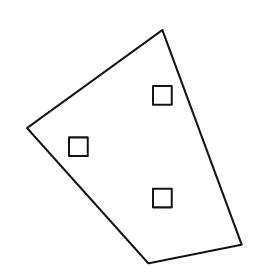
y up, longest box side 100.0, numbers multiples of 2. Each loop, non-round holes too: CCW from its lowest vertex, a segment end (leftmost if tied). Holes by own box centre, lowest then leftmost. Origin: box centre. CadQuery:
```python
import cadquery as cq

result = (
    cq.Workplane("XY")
    .moveTo(6.0, -50.0)
    .lineTo(46.0, -42.0)
    .lineTo(12.0, 50.0)
    .lineTo(-46.0, 8.0)
    .close()
    .moveTo(8.0, -26.0)
    .lineTo(16.0, -26.0)
    .lineTo(16.0, -18.0)
    .lineTo(8.0, -18.0)
    .close()
    .moveTo(-28.0, -4.0)
    .lineTo(-20.0, -4.0)
    .lineTo(-20.0, 4.0)
    .lineTo(-28.0, 4.0)
    .close()
    .moveTo(8.0, 18.0)
    .lineTo(16.0, 18.0)
    .lineTo(16.0, 26.0)
    .lineTo(8.0, 26.0)
    .close()
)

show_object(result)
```